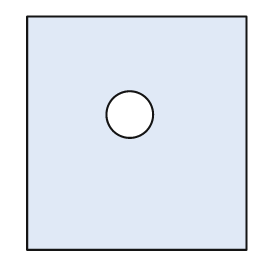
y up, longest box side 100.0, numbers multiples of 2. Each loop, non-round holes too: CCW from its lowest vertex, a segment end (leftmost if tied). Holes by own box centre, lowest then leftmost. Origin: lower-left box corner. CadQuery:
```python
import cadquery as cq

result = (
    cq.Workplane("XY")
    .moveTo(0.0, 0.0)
    .lineTo(94.0, 0.0)
    .lineTo(94.0, 100.0)
    .lineTo(0.0, 100.0)
    .close()
    .moveTo(44.0, 58.0)
    .circle(10.0)
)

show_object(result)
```